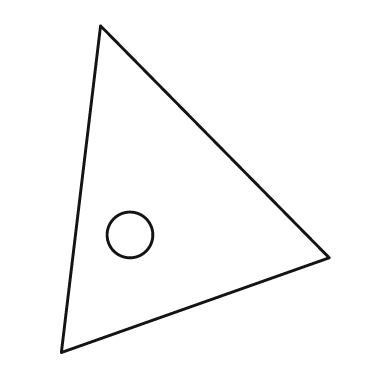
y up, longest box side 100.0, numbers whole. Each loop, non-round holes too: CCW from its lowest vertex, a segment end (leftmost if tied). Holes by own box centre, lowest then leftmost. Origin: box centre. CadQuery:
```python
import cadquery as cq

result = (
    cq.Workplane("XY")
    .moveTo(-41.0, -50.0)
    .lineTo(41.0, -21.0)
    .lineTo(-29.0, 50.0)
    .close()
    .moveTo(-20.0, -14.0)
    .circle(7.0)
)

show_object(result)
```